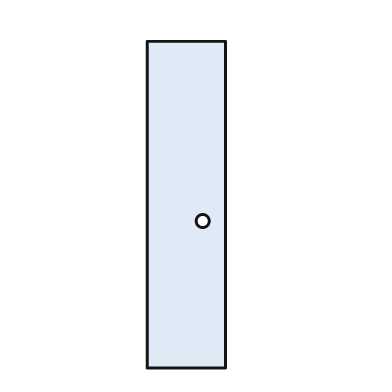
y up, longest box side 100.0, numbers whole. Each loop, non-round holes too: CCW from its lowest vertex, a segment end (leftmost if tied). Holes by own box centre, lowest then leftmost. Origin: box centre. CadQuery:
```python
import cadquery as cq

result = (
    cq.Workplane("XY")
    .moveTo(-12.0, -50.0)
    .lineTo(12.0, -50.0)
    .lineTo(12.0, 50.0)
    .lineTo(-12.0, 50.0)
    .close()
    .moveTo(5.0, -5.0)
    .circle(2.0)
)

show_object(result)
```